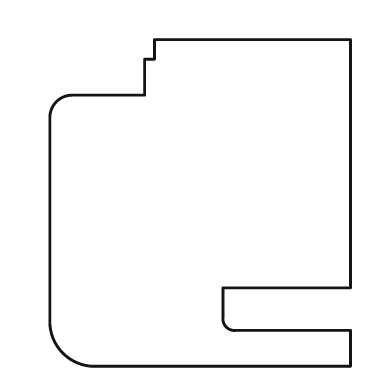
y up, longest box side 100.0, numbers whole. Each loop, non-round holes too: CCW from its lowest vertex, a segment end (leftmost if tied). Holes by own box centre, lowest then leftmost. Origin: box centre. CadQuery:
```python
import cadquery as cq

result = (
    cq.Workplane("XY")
    .moveTo(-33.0, -50.0)
    .lineTo(46.0, -50.0)
    .lineTo(46.0, -39.0)
    .lineTo(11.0, -39.0)
    .threePointArc((8.0, -38.0), (7.0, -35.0))
    .lineTo(7.0, -26.0)
    .lineTo(46.0, -26.0)
    .lineTo(46.0, 50.0)
    .lineTo(-14.0, 50.0)
    .lineTo(-14.0, 44.0)
    .lineTo(-17.0, 44.0)
    .lineTo(-17.0, 33.0)
    .lineTo(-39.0, 33.0)
    .threePointArc((-44.0, 31.0), (-46.0, 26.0))
    .lineTo(-46.0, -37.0)
    .threePointArc((-42.0, -46.0), (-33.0, -50.0))
    .close()
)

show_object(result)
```